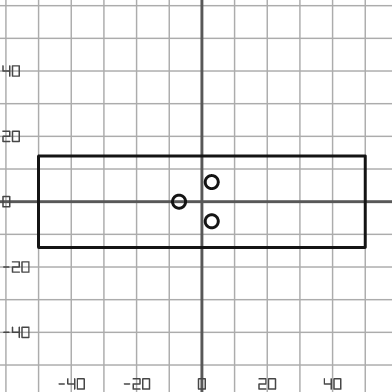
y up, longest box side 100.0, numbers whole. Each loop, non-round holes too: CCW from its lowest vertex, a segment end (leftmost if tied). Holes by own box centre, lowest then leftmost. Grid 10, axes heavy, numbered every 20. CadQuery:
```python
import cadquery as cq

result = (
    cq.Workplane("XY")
    .moveTo(-50.0, -14.0)
    .lineTo(50.0, -14.0)
    .lineTo(50.0, 14.0)
    .lineTo(-50.0, 14.0)
    .close()
    .moveTo(3.0, -6.0)
    .circle(2.0)
    .moveTo(-7.0, 0.0)
    .circle(2.0)
    .moveTo(3.0, 6.0)
    .circle(2.0)
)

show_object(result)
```